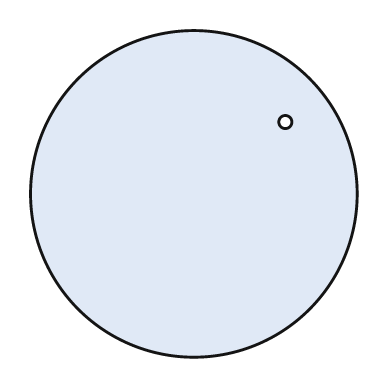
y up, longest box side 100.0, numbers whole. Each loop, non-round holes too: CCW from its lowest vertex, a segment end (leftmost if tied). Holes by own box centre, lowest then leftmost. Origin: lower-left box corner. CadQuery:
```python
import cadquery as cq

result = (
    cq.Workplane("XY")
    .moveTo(50.0, 50.0)
    .circle(50.0)
    .moveTo(78.0, 72.0)
    .circle(2.0)
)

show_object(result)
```